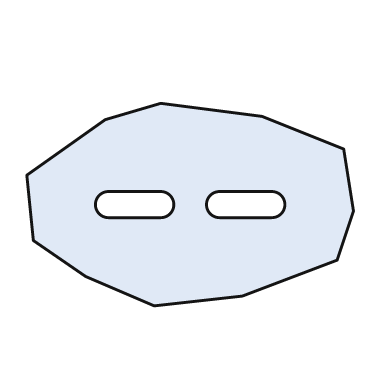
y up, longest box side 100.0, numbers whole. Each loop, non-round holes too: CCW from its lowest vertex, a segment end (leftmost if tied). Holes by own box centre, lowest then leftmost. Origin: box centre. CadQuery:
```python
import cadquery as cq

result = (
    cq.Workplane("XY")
    .moveTo(-11.0, -31.0)
    .lineTo(16.0, -28.0)
    .lineTo(45.0, -17.0)
    .lineTo(50.0, -2.0)
    .lineTo(47.0, 17.0)
    .lineTo(22.0, 27.0)
    .lineTo(-9.0, 31.0)
    .lineTo(-26.0, 26.0)
    .lineTo(-50.0, 9.0)
    .lineTo(-48.0, -11.0)
    .lineTo(-32.0, -22.0)
    .close()
    .moveTo(-25.0, -4.0)
    .lineTo(-9.0, -4.0)
    .threePointArc((-5.0, 0.0), (-9.0, 4.0))
    .lineTo(-25.0, 4.0)
    .threePointArc((-29.0, 0.0), (-25.0, -4.0))
    .close()
    .moveTo(9.0, -4.0)
    .lineTo(25.0, -4.0)
    .threePointArc((29.0, 0.0), (25.0, 4.0))
    .lineTo(9.0, 4.0)
    .threePointArc((5.0, 0.0), (9.0, -4.0))
    .close()
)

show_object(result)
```